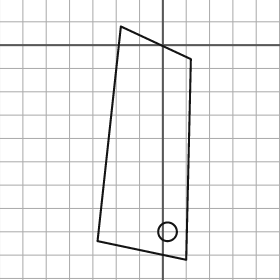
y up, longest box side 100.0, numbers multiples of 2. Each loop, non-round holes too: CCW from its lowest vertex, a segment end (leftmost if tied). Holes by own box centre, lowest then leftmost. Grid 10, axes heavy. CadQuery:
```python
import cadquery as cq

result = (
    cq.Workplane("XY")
    .moveTo(10.0, -92.0)
    .lineTo(12.0, -6.0)
    .lineTo(-18.0, 8.0)
    .lineTo(-28.0, -84.0)
    .close()
    .moveTo(2.0, -80.0)
    .circle(4.0)
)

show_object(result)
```